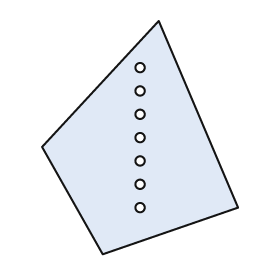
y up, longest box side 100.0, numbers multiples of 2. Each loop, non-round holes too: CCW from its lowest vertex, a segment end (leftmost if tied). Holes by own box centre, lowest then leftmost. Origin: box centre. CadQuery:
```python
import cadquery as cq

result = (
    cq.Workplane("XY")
    .moveTo(-16.0, -50.0)
    .lineTo(42.0, -30.0)
    .lineTo(8.0, 50.0)
    .lineTo(-42.0, -4.0)
    .close()
    .moveTo(0.0, -30.0)
    .circle(2.0)
    .moveTo(0.0, -20.0)
    .circle(2.0)
    .moveTo(0.0, -10.0)
    .circle(2.0)
    .moveTo(0.0, 0.0)
    .circle(2.0)
    .moveTo(0.0, 10.0)
    .circle(2.0)
    .moveTo(0.0, 20.0)
    .circle(2.0)
    .moveTo(0.0, 30.0)
    .circle(2.0)
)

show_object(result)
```